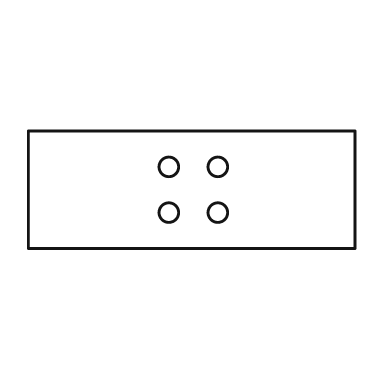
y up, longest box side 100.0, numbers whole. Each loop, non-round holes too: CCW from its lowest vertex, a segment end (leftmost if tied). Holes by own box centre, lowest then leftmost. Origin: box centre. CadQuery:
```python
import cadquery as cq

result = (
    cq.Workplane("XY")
    .moveTo(-50.0, -18.0)
    .lineTo(50.0, -18.0)
    .lineTo(50.0, 18.0)
    .lineTo(-50.0, 18.0)
    .close()
    .moveTo(-7.0, -7.0)
    .circle(3.0)
    .moveTo(8.0, -7.0)
    .circle(3.0)
    .moveTo(-7.0, 7.0)
    .circle(3.0)
    .moveTo(8.0, 7.0)
    .circle(3.0)
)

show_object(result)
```